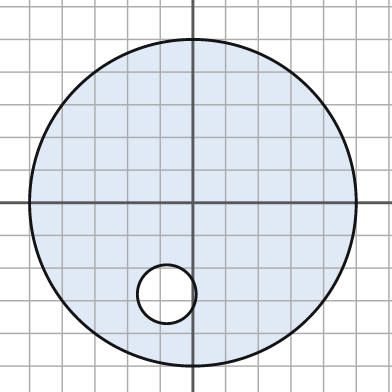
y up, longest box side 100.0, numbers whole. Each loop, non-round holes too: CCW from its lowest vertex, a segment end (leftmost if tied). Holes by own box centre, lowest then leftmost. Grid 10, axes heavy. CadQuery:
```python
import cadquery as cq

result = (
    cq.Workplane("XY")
    .moveTo(0.0, 0.0)
    .circle(50.0)
    .moveTo(-8.0, -28.0)
    .circle(9.0)
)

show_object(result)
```